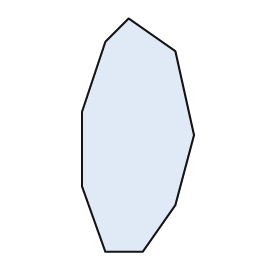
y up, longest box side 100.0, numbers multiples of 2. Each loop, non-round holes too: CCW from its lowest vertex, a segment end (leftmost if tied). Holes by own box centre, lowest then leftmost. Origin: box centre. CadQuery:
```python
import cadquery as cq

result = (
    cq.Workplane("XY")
    .moveTo(-14.0, -50.0)
    .lineTo(2.0, -50.0)
    .lineTo(16.0, -30.0)
    .lineTo(24.0, 0.0)
    .lineTo(16.0, 36.0)
    .lineTo(-4.0, 50.0)
    .lineTo(-14.0, 40.0)
    .lineTo(-24.0, 10.0)
    .lineTo(-24.0, -22.0)
    .close()
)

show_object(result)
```